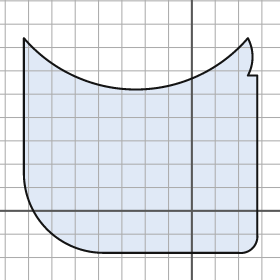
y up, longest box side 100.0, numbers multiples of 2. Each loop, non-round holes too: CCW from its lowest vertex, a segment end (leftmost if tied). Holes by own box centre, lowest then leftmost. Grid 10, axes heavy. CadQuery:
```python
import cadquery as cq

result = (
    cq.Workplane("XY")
    .moveTo(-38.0, -18.0)
    .lineTo(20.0, -18.0)
    .threePointArc((26.0, -16.0), (28.0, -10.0))
    .lineTo(28.0, 58.0)
    .lineTo(24.0, 58.0)
    .threePointArc((26.0, 66.0), (24.0, 74.0))
    .threePointArc((-24.0, 52.0), (-72.0, 74.0))
    .lineTo(-72.0, 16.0)
    .threePointArc((-62.0, -8.0), (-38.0, -18.0))
    .close()
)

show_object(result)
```